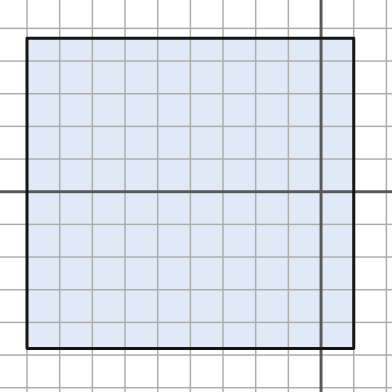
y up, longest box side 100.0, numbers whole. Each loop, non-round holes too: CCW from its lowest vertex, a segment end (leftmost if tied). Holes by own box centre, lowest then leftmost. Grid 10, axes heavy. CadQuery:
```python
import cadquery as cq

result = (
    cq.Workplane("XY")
    .moveTo(-90.0, -48.0)
    .lineTo(10.0, -48.0)
    .lineTo(10.0, 47.0)
    .lineTo(-90.0, 47.0)
    .close()
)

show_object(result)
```